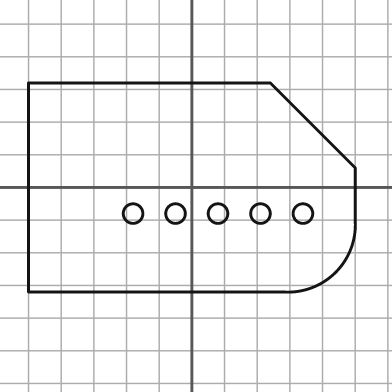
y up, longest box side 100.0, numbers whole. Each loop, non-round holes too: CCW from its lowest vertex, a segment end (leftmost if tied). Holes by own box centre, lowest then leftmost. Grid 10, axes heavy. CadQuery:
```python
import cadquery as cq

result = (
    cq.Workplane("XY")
    .moveTo(-50.0, -32.0)
    .lineTo(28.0, -32.0)
    .threePointArc((44.0, -26.0), (50.0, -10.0))
    .lineTo(50.0, 6.0)
    .lineTo(24.0, 32.0)
    .lineTo(-50.0, 32.0)
    .close()
    .moveTo(-18.0, -8.0)
    .circle(3.0)
    .moveTo(-5.0, -8.0)
    .circle(3.0)
    .moveTo(8.0, -8.0)
    .circle(3.0)
    .moveTo(21.0, -8.0)
    .circle(3.0)
    .moveTo(34.0, -8.0)
    .circle(3.0)
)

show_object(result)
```